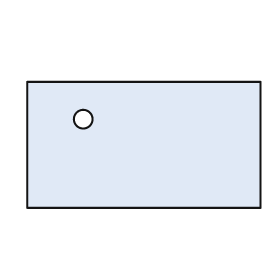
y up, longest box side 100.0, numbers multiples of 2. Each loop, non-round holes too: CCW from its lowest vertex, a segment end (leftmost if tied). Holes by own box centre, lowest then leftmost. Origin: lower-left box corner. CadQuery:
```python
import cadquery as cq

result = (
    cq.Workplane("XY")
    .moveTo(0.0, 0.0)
    .lineTo(100.0, 0.0)
    .lineTo(100.0, 54.0)
    .lineTo(0.0, 54.0)
    .close()
    .moveTo(24.0, 38.0)
    .circle(4.0)
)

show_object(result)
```